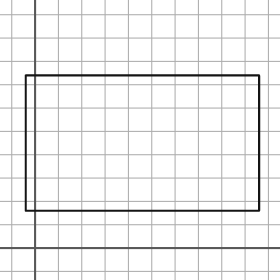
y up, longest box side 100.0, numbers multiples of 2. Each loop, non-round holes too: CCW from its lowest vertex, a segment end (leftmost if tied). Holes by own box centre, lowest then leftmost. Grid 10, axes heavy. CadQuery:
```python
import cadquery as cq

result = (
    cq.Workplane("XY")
    .moveTo(-4.0, 16.0)
    .lineTo(96.0, 16.0)
    .lineTo(96.0, 74.0)
    .lineTo(-4.0, 74.0)
    .close()
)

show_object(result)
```